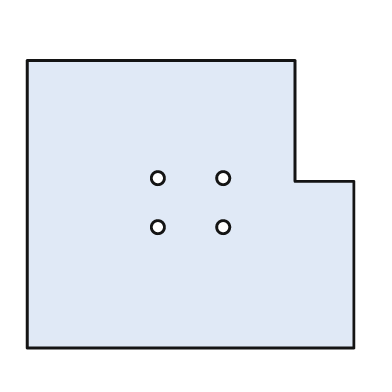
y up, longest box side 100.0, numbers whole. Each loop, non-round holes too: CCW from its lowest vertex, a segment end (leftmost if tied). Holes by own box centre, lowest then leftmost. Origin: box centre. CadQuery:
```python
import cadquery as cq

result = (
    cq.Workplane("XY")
    .moveTo(-50.0, -44.0)
    .lineTo(50.0, -44.0)
    .lineTo(50.0, 7.0)
    .lineTo(32.0, 7.0)
    .lineTo(32.0, 44.0)
    .lineTo(-50.0, 44.0)
    .close()
    .moveTo(-10.0, -7.0)
    .circle(2.0)
    .moveTo(10.0, -7.0)
    .circle(2.0)
    .moveTo(-10.0, 8.0)
    .circle(2.0)
    .moveTo(10.0, 8.0)
    .circle(2.0)
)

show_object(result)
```